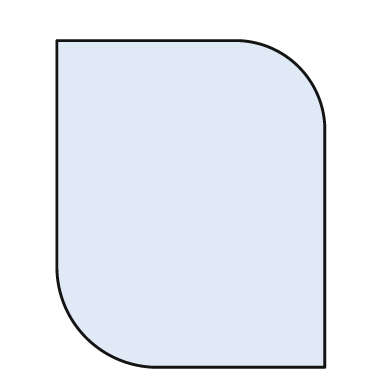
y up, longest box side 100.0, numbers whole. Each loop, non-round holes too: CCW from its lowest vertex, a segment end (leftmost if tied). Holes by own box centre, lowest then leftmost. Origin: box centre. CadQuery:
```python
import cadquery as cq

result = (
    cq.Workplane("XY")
    .moveTo(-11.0, -50.0)
    .lineTo(41.0, -50.0)
    .lineTo(41.0, 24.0)
    .threePointArc((33.0, 42.0), (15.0, 50.0))
    .lineTo(-41.0, 50.0)
    .lineTo(-41.0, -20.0)
    .threePointArc((-32.0, -41.0), (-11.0, -50.0))
    .close()
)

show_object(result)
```